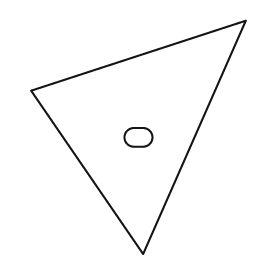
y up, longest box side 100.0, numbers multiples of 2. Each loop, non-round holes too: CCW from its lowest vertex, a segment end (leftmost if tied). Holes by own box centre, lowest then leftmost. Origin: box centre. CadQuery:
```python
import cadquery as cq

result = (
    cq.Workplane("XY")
    .moveTo(2.0, -50.0)
    .lineTo(46.0, 50.0)
    .lineTo(-46.0, 20.0)
    .close()
    .moveTo(-2.0, -4.0)
    .lineTo(2.0, -4.0)
    .threePointArc((6.0, 0.0), (2.0, 4.0))
    .lineTo(-2.0, 4.0)
    .threePointArc((-6.0, 0.0), (-2.0, -4.0))
    .close()
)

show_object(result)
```